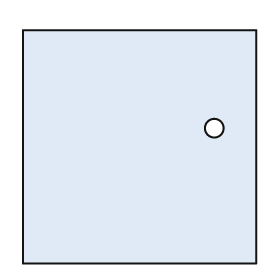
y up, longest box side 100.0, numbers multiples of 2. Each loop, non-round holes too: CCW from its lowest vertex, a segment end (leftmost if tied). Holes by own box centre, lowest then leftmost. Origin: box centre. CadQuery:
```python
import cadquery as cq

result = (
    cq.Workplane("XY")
    .moveTo(-50.0, -50.0)
    .lineTo(50.0, -50.0)
    .lineTo(50.0, 50.0)
    .lineTo(-50.0, 50.0)
    .close()
    .moveTo(32.0, 8.0)
    .circle(4.0)
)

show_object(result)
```